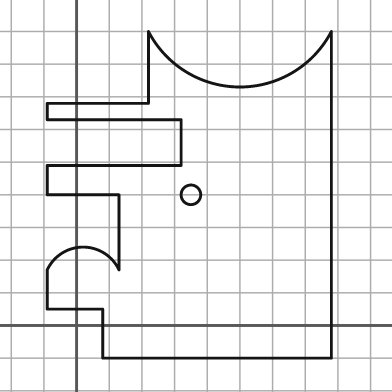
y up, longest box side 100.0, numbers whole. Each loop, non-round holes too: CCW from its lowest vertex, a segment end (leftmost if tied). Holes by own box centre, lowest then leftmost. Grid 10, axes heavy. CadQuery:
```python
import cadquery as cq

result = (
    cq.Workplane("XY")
    .moveTo(8.0, -10.0)
    .lineTo(78.0, -10.0)
    .lineTo(78.0, 90.0)
    .threePointArc((50.0, 73.0), (22.0, 90.0))
    .lineTo(22.0, 68.0)
    .lineTo(-9.0, 68.0)
    .lineTo(-9.0, 63.0)
    .lineTo(32.0, 63.0)
    .lineTo(32.0, 49.0)
    .lineTo(-9.0, 49.0)
    .lineTo(-9.0, 40.0)
    .lineTo(13.0, 40.0)
    .lineTo(13.0, 17.0)
    .threePointArc((2.0, 24.0), (-9.0, 17.0))
    .lineTo(-9.0, 5.0)
    .lineTo(8.0, 5.0)
    .close()
    .moveTo(35.0, 40.0)
    .circle(3.0)
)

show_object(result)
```